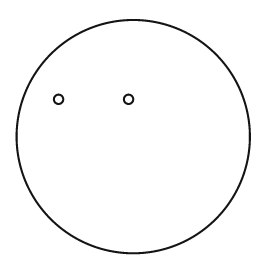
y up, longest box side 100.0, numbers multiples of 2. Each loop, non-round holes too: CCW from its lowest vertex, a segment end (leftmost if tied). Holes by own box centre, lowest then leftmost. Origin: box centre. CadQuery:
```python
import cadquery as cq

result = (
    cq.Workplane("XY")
    .moveTo(0.0, 0.0)
    .circle(50.0)
    .moveTo(-32.0, 16.0)
    .circle(2.0)
    .moveTo(-2.0, 16.0)
    .circle(2.0)
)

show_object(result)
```